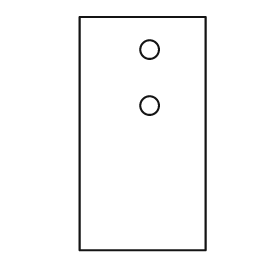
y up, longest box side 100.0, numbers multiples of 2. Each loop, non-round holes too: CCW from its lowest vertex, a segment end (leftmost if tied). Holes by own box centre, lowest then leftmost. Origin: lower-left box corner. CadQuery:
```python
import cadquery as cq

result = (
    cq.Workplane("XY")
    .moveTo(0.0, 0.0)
    .lineTo(54.0, 0.0)
    .lineTo(54.0, 100.0)
    .lineTo(0.0, 100.0)
    .close()
    .moveTo(30.0, 62.0)
    .circle(4.0)
    .moveTo(30.0, 86.0)
    .circle(4.0)
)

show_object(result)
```